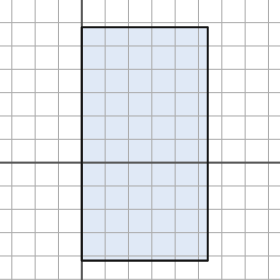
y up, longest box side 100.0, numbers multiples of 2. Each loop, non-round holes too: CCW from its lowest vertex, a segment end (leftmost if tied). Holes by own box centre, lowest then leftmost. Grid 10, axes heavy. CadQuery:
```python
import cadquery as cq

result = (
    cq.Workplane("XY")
    .moveTo(0.0, -42.0)
    .lineTo(54.0, -42.0)
    .lineTo(54.0, 58.0)
    .lineTo(0.0, 58.0)
    .close()
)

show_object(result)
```